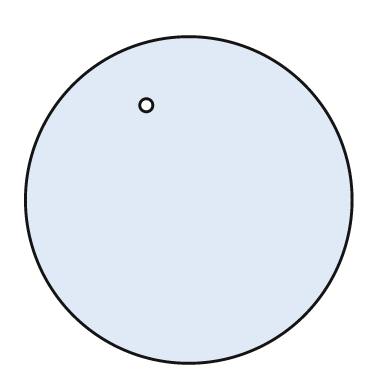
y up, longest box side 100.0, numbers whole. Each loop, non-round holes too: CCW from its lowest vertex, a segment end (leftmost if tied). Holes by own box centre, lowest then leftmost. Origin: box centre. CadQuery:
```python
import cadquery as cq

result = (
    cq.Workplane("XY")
    .moveTo(0.0, 0.0)
    .circle(50.0)
    .moveTo(-13.0, 29.0)
    .circle(2.0)
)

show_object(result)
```